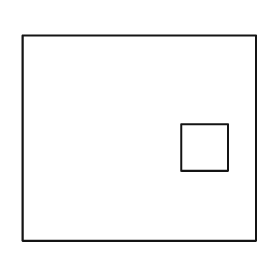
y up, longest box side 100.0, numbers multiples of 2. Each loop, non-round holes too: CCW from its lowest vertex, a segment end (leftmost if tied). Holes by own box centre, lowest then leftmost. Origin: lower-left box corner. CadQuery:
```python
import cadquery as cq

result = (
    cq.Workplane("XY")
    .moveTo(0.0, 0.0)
    .lineTo(100.0, 0.0)
    .lineTo(100.0, 88.0)
    .lineTo(0.0, 88.0)
    .close()
    .moveTo(68.0, 30.0)
    .lineTo(88.0, 30.0)
    .lineTo(88.0, 50.0)
    .lineTo(68.0, 50.0)
    .close()
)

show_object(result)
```